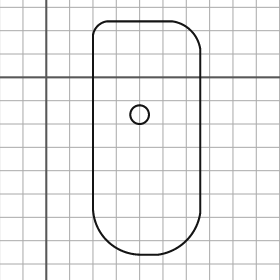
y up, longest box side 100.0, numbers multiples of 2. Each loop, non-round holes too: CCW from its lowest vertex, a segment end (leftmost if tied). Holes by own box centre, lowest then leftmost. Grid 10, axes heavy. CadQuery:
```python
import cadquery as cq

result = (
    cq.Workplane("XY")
    .moveTo(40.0, -76.0)
    .lineTo(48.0, -76.0)
    .threePointArc((60.0, -70.0), (66.0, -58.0))
    .lineTo(66.0, 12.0)
    .threePointArc((62.0, 20.0), (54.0, 24.0))
    .lineTo(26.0, 24.0)
    .threePointArc((22.0, 22.0), (20.0, 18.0))
    .lineTo(20.0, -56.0)
    .threePointArc((26.0, -70.0), (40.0, -76.0))
    .close()
    .moveTo(40.0, -16.0)
    .circle(4.0)
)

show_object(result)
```